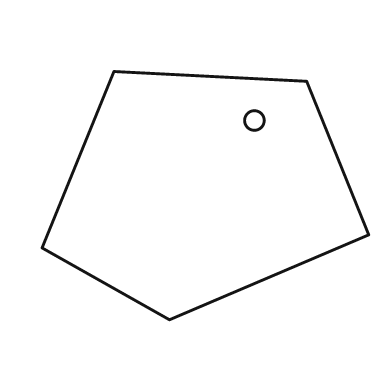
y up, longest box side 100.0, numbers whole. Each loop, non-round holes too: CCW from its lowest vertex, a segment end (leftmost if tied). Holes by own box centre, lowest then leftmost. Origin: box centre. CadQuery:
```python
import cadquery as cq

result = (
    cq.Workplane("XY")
    .moveTo(-11.0, -38.0)
    .lineTo(50.0, -12.0)
    .lineTo(31.0, 35.0)
    .lineTo(-28.0, 38.0)
    .lineTo(-50.0, -16.0)
    .close()
    .moveTo(15.0, 23.0)
    .circle(3.0)
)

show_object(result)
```